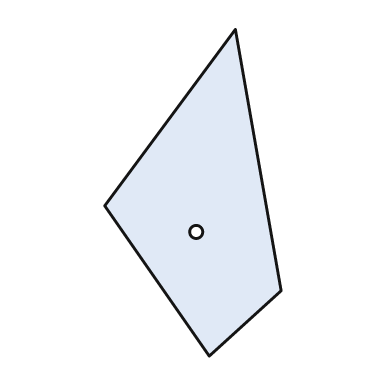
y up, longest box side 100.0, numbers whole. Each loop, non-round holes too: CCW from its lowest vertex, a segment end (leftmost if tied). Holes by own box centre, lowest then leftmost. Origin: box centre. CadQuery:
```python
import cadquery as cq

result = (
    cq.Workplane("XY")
    .moveTo(5.0, -50.0)
    .lineTo(27.0, -30.0)
    .lineTo(13.0, 50.0)
    .lineTo(-27.0, -4.0)
    .close()
    .moveTo(1.0, -12.0)
    .circle(2.0)
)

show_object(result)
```